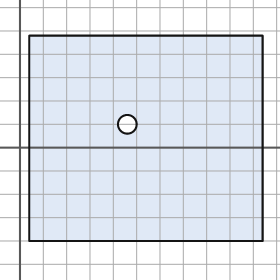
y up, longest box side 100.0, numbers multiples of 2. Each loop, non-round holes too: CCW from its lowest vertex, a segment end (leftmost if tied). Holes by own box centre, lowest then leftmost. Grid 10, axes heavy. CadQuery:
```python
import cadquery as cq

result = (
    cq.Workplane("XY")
    .moveTo(4.0, -40.0)
    .lineTo(104.0, -40.0)
    .lineTo(104.0, 48.0)
    .lineTo(4.0, 48.0)
    .close()
    .moveTo(46.0, 10.0)
    .circle(4.0)
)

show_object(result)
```